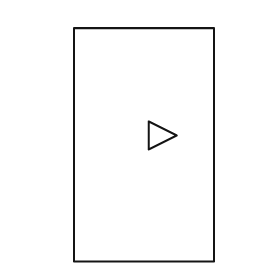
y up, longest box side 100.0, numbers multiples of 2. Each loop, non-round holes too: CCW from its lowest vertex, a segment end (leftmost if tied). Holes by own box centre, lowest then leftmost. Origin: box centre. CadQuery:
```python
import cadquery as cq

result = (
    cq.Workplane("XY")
    .moveTo(-30.0, -50.0)
    .lineTo(30.0, -50.0)
    .lineTo(30.0, 50.0)
    .lineTo(-30.0, 50.0)
    .close()
    .moveTo(2.0, -2.0)
    .lineTo(14.0, 4.0)
    .lineTo(2.0, 10.0)
    .close()
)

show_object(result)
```